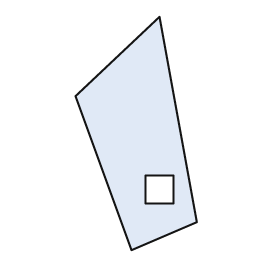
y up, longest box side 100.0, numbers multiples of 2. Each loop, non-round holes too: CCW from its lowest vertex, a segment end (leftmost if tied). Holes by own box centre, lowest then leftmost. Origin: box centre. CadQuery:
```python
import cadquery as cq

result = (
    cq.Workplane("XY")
    .moveTo(-2.0, -50.0)
    .lineTo(26.0, -38.0)
    .lineTo(10.0, 50.0)
    .lineTo(-26.0, 16.0)
    .close()
    .moveTo(4.0, -30.0)
    .lineTo(16.0, -30.0)
    .lineTo(16.0, -18.0)
    .lineTo(4.0, -18.0)
    .close()
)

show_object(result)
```